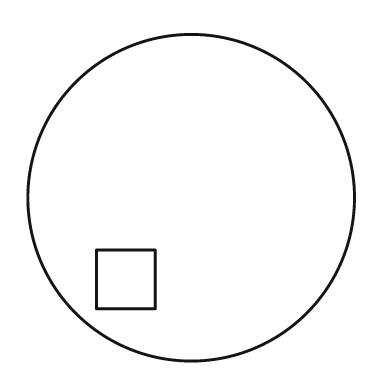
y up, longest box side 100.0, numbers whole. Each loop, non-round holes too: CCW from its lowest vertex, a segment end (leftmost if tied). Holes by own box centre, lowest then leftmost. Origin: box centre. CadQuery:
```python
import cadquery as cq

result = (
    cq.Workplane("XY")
    .moveTo(0.0, 0.0)
    .circle(50.0)
    .moveTo(-29.0, -34.0)
    .lineTo(-11.0, -34.0)
    .lineTo(-11.0, -16.0)
    .lineTo(-29.0, -16.0)
    .close()
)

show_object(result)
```